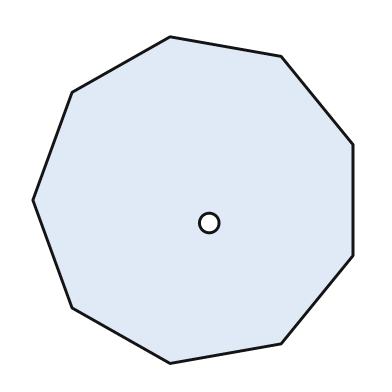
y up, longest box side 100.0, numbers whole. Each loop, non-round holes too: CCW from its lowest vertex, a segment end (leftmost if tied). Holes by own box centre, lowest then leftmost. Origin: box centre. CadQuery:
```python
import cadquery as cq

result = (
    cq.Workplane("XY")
    .moveTo(-7.0, -50.0)
    .lineTo(27.0, -44.0)
    .lineTo(49.0, -17.0)
    .lineTo(49.0, 17.0)
    .lineTo(27.0, 44.0)
    .lineTo(-7.0, 50.0)
    .lineTo(-37.0, 33.0)
    .lineTo(-49.0, 0.0)
    .lineTo(-37.0, -33.0)
    .close()
    .moveTo(5.0, -7.0)
    .circle(3.0)
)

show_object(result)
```